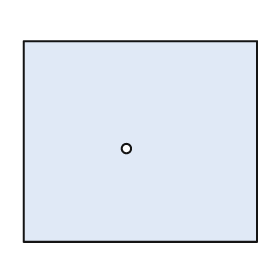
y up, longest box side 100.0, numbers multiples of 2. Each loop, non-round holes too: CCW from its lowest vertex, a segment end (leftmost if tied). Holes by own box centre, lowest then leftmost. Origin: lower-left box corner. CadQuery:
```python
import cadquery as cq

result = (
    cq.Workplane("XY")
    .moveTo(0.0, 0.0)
    .lineTo(100.0, 0.0)
    .lineTo(100.0, 86.0)
    .lineTo(0.0, 86.0)
    .close()
    .moveTo(44.0, 40.0)
    .circle(2.0)
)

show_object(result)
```